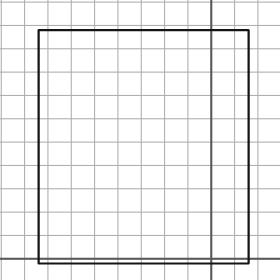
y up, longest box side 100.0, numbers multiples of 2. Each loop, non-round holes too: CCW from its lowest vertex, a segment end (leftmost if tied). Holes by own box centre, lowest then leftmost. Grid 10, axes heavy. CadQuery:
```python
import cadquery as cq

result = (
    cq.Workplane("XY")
    .moveTo(-74.0, -2.0)
    .lineTo(16.0, -2.0)
    .lineTo(16.0, 98.0)
    .lineTo(-74.0, 98.0)
    .close()
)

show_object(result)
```